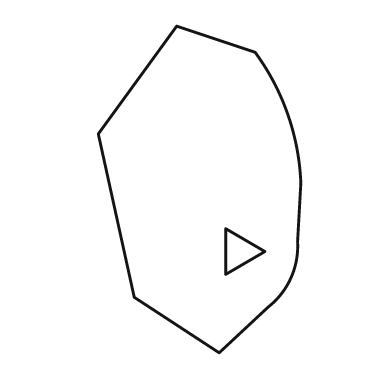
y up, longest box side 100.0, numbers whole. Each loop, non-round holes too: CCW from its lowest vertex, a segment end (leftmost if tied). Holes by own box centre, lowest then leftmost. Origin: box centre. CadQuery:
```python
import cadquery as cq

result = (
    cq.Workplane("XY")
    .moveTo(6.0, -50.0)
    .lineTo(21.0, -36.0)
    .threePointArc((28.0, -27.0), (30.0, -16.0))
    .lineTo(31.0, 2.0)
    .threePointArc((27.0, 23.0), (17.0, 42.0))
    .lineTo(-7.0, 50.0)
    .lineTo(-31.0, 17.0)
    .lineTo(-20.0, -33.0)
    .close()
    .moveTo(8.0, -26.0)
    .lineTo(20.0, -19.0)
    .lineTo(8.0, -12.0)
    .close()
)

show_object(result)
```